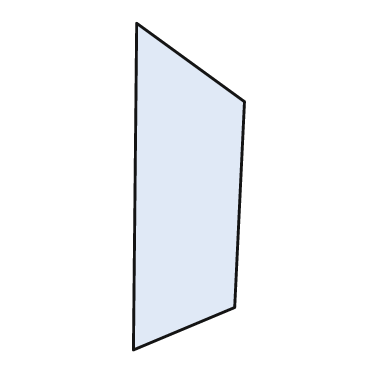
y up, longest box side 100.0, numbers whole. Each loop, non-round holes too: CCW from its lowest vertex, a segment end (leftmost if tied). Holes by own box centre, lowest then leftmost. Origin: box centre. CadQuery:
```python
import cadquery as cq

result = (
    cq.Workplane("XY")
    .moveTo(-17.0, -50.0)
    .lineTo(14.0, -37.0)
    .lineTo(17.0, 26.0)
    .lineTo(-16.0, 50.0)
    .close()
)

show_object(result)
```